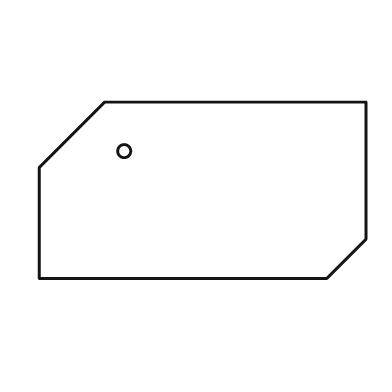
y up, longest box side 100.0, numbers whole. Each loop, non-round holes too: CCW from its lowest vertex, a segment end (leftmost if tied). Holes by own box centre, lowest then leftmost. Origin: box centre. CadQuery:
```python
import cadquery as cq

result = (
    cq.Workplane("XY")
    .moveTo(-50.0, -27.0)
    .lineTo(38.0, -27.0)
    .lineTo(50.0, -15.0)
    .lineTo(50.0, 27.0)
    .lineTo(-30.0, 27.0)
    .lineTo(-50.0, 7.0)
    .close()
    .moveTo(-24.0, 12.0)
    .circle(2.0)
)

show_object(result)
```